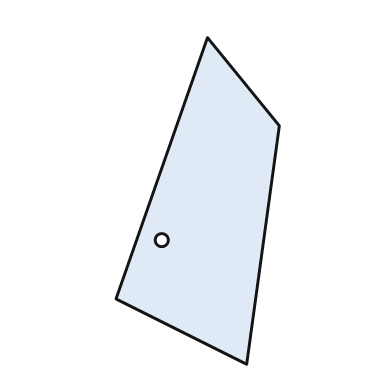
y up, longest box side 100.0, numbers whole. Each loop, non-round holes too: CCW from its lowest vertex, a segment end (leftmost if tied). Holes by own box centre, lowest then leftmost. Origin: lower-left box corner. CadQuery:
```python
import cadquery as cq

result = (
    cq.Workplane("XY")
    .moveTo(40.0, 0.0)
    .lineTo(50.0, 73.0)
    .lineTo(28.0, 100.0)
    .lineTo(0.0, 20.0)
    .close()
    .moveTo(14.0, 38.0)
    .circle(2.0)
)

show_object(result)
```